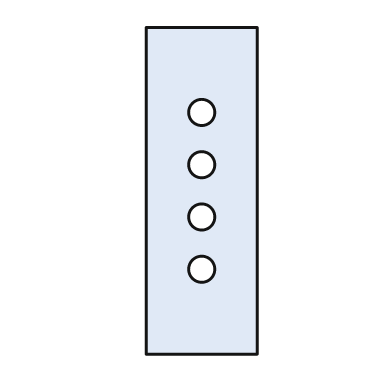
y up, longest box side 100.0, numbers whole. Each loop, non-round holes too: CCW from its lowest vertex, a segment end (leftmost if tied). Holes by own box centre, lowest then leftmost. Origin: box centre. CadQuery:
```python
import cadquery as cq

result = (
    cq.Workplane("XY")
    .moveTo(-17.0, -50.0)
    .lineTo(17.0, -50.0)
    .lineTo(17.0, 50.0)
    .lineTo(-17.0, 50.0)
    .close()
    .moveTo(0.0, -24.0)
    .circle(4.0)
    .moveTo(0.0, -8.0)
    .circle(4.0)
    .moveTo(0.0, 8.0)
    .circle(4.0)
    .moveTo(0.0, 24.0)
    .circle(4.0)
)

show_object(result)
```